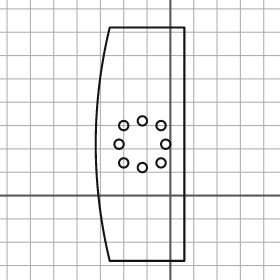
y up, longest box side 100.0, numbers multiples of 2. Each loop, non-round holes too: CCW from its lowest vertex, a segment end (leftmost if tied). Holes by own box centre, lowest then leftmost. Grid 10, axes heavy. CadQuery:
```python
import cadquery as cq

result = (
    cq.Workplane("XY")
    .moveTo(-26.0, -28.0)
    .lineTo(6.0, -28.0)
    .lineTo(6.0, 72.0)
    .lineTo(-26.0, 72.0)
    .threePointArc((-32.0, 22.0), (-26.0, -28.0))
    .close()
    .moveTo(-12.0, 12.0)
    .circle(2.0)
    .moveTo(-20.0, 14.0)
    .circle(2.0)
    .moveTo(-4.0, 14.0)
    .circle(2.0)
    .moveTo(-22.0, 22.0)
    .circle(2.0)
    .moveTo(-2.0, 22.0)
    .circle(2.0)
    .moveTo(-20.0, 30.0)
    .circle(2.0)
    .moveTo(-4.0, 30.0)
    .circle(2.0)
    .moveTo(-12.0, 32.0)
    .circle(2.0)
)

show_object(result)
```